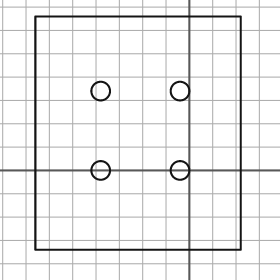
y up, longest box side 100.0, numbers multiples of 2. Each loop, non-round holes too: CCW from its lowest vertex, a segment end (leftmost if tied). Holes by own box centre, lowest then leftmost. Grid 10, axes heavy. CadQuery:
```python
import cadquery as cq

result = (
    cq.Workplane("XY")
    .moveTo(-66.0, -34.0)
    .lineTo(22.0, -34.0)
    .lineTo(22.0, 66.0)
    .lineTo(-66.0, 66.0)
    .close()
    .moveTo(-38.0, 0.0)
    .circle(4.0)
    .moveTo(-4.0, 0.0)
    .circle(4.0)
    .moveTo(-38.0, 34.0)
    .circle(4.0)
    .moveTo(-4.0, 34.0)
    .circle(4.0)
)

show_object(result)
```